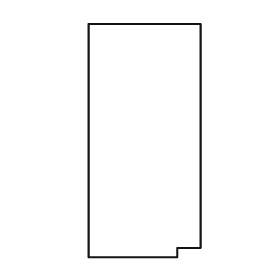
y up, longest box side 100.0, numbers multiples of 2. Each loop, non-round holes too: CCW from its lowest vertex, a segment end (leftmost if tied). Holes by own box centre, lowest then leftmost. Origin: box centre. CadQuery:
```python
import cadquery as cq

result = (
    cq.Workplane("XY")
    .moveTo(-24.0, -50.0)
    .lineTo(14.0, -50.0)
    .lineTo(14.0, -46.0)
    .lineTo(24.0, -46.0)
    .lineTo(24.0, 50.0)
    .lineTo(-24.0, 50.0)
    .close()
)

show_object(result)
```